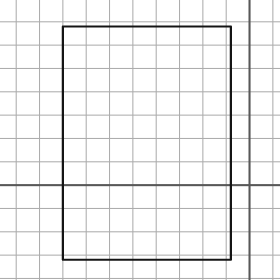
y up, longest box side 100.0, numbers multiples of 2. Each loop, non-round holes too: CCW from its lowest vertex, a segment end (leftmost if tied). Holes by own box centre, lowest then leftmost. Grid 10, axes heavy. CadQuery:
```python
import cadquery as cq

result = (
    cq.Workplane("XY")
    .moveTo(-80.0, -32.0)
    .lineTo(-8.0, -32.0)
    .lineTo(-8.0, 68.0)
    .lineTo(-80.0, 68.0)
    .close()
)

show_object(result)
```